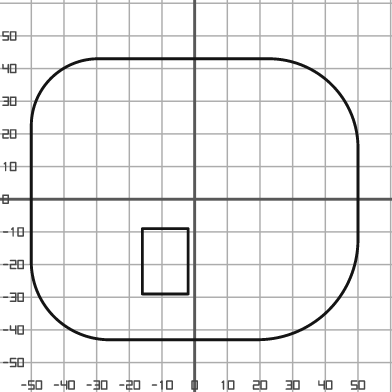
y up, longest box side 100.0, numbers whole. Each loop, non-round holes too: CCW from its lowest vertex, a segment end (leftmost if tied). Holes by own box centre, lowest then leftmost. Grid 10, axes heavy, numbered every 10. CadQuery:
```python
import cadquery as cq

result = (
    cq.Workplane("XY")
    .moveTo(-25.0, -43.0)
    .lineTo(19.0, -43.0)
    .threePointArc((41.0, -34.0), (50.0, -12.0))
    .lineTo(50.0, 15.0)
    .threePointArc((42.0, 35.0), (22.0, 43.0))
    .lineTo(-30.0, 43.0)
    .threePointArc((-44.0, 37.0), (-50.0, 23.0))
    .lineTo(-50.0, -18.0)
    .threePointArc((-43.0, -36.0), (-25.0, -43.0))
    .close()
    .moveTo(-16.0, -29.0)
    .lineTo(-2.0, -29.0)
    .lineTo(-2.0, -9.0)
    .lineTo(-16.0, -9.0)
    .close()
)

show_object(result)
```